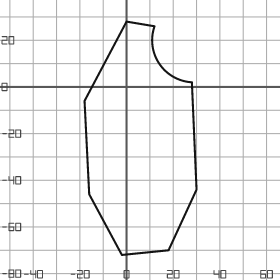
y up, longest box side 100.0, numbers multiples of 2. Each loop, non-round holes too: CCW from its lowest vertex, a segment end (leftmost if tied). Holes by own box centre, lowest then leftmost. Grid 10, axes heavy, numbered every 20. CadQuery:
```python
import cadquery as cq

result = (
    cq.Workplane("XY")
    .moveTo(-2.0, -72.0)
    .lineTo(18.0, -70.0)
    .lineTo(30.0, -44.0)
    .lineTo(28.0, 2.0)
    .threePointArc((14.0, 10.0), (12.0, 26.0))
    .lineTo(0.0, 28.0)
    .lineTo(-18.0, -6.0)
    .lineTo(-16.0, -46.0)
    .close()
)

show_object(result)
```